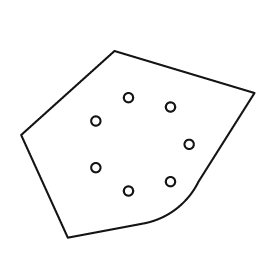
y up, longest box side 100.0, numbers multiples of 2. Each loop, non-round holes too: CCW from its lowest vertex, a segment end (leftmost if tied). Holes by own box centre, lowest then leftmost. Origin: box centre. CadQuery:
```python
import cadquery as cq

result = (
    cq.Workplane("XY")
    .moveTo(-30.0, -40.0)
    .lineTo(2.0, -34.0)
    .threePointArc((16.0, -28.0), (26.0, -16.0))
    .lineTo(50.0, 22.0)
    .lineTo(-10.0, 40.0)
    .lineTo(-50.0, 4.0)
    .close()
    .moveTo(-4.0, -20.0)
    .circle(2.0)
    .moveTo(14.0, -16.0)
    .circle(2.0)
    .moveTo(-18.0, -10.0)
    .circle(2.0)
    .moveTo(22.0, 0.0)
    .circle(2.0)
    .moveTo(-18.0, 10.0)
    .circle(2.0)
    .moveTo(14.0, 16.0)
    .circle(2.0)
    .moveTo(-4.0, 20.0)
    .circle(2.0)
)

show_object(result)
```